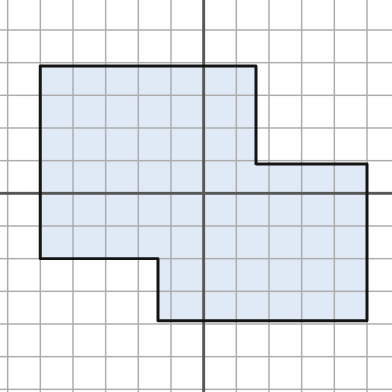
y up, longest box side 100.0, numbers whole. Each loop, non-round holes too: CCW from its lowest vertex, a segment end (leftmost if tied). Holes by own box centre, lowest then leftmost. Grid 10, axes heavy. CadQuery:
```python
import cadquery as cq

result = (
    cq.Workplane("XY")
    .moveTo(-14.0, -39.0)
    .lineTo(50.0, -39.0)
    .lineTo(50.0, 9.0)
    .lineTo(16.0, 9.0)
    .lineTo(16.0, 39.0)
    .lineTo(-50.0, 39.0)
    .lineTo(-50.0, -20.0)
    .lineTo(-14.0, -20.0)
    .close()
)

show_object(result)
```